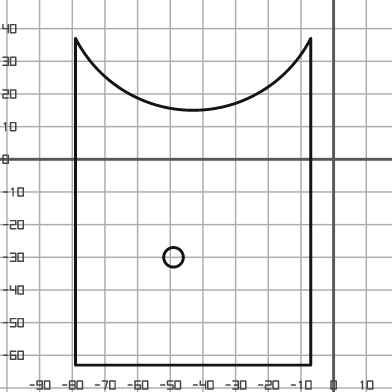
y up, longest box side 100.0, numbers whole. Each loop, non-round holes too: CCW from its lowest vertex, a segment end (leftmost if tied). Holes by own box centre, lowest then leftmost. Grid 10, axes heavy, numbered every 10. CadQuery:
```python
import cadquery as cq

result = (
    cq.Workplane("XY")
    .moveTo(-79.0, -63.0)
    .lineTo(-7.0, -63.0)
    .lineTo(-7.0, 37.0)
    .threePointArc((-43.0, 15.0), (-79.0, 37.0))
    .close()
    .moveTo(-49.0, -30.0)
    .circle(3.0)
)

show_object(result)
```